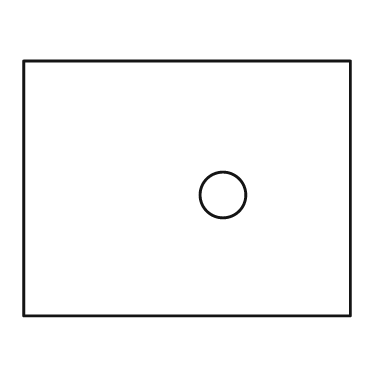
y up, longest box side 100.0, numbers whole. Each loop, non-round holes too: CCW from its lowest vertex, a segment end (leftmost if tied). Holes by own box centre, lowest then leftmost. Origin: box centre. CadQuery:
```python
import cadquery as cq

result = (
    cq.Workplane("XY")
    .moveTo(-50.0, -39.0)
    .lineTo(50.0, -39.0)
    .lineTo(50.0, 39.0)
    .lineTo(-50.0, 39.0)
    .close()
    .moveTo(11.0, -2.0)
    .circle(7.0)
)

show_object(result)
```